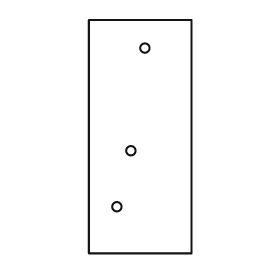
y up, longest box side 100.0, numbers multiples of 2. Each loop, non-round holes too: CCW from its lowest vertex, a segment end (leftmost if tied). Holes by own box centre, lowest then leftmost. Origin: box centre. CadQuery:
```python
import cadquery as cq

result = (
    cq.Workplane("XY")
    .moveTo(-22.0, -50.0)
    .lineTo(22.0, -50.0)
    .lineTo(22.0, 50.0)
    .lineTo(-22.0, 50.0)
    .close()
    .moveTo(-10.0, -30.0)
    .circle(2.0)
    .moveTo(-4.0, -6.0)
    .circle(2.0)
    .moveTo(2.0, 38.0)
    .circle(2.0)
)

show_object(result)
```